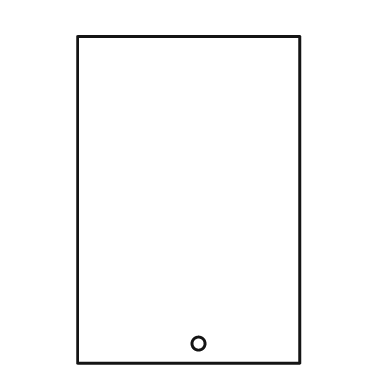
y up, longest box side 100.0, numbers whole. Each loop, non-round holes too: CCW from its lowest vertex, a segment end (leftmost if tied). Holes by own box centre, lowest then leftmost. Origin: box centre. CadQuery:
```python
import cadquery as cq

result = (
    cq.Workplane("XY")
    .moveTo(-34.0, -50.0)
    .lineTo(34.0, -50.0)
    .lineTo(34.0, 50.0)
    .lineTo(-34.0, 50.0)
    .close()
    .moveTo(3.0, -44.0)
    .circle(2.0)
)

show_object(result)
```